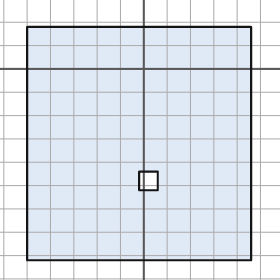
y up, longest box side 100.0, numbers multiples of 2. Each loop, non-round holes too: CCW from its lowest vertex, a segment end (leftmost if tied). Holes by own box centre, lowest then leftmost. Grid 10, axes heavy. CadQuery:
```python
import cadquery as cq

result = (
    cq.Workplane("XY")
    .moveTo(-50.0, -82.0)
    .lineTo(46.0, -82.0)
    .lineTo(46.0, 18.0)
    .lineTo(-50.0, 18.0)
    .close()
    .moveTo(-2.0, -52.0)
    .lineTo(6.0, -52.0)
    .lineTo(6.0, -44.0)
    .lineTo(-2.0, -44.0)
    .close()
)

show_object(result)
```